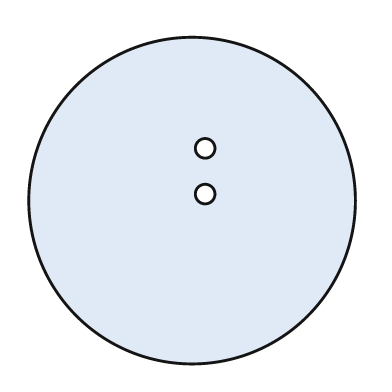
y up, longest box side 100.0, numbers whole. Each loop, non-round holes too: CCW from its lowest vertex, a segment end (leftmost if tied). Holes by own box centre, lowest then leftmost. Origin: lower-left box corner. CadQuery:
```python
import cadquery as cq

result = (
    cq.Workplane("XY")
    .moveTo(50.0, 50.0)
    .circle(50.0)
    .moveTo(54.0, 52.0)
    .circle(3.0)
    .moveTo(54.0, 66.0)
    .circle(3.0)
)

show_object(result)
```